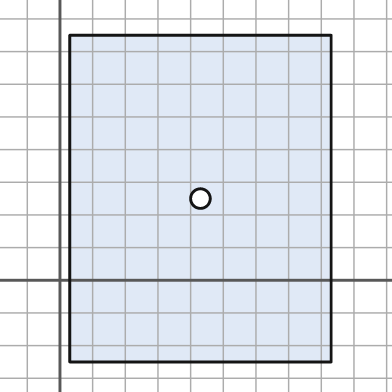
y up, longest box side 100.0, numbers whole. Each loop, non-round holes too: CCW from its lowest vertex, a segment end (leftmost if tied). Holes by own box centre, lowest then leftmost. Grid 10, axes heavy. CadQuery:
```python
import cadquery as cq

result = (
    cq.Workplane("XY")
    .moveTo(3.0, -25.0)
    .lineTo(83.0, -25.0)
    .lineTo(83.0, 75.0)
    .lineTo(3.0, 75.0)
    .close()
    .moveTo(43.0, 25.0)
    .circle(3.0)
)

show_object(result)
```